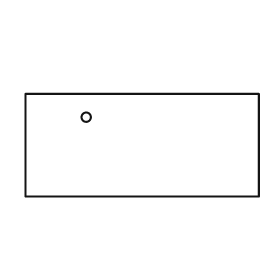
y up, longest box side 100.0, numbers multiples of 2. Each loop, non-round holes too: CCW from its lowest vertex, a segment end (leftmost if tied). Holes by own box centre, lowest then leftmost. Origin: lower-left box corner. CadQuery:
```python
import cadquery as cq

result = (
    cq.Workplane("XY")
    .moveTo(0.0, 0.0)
    .lineTo(100.0, 0.0)
    .lineTo(100.0, 44.0)
    .lineTo(0.0, 44.0)
    .close()
    .moveTo(26.0, 34.0)
    .circle(2.0)
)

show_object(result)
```